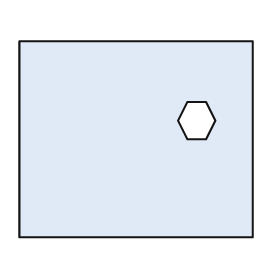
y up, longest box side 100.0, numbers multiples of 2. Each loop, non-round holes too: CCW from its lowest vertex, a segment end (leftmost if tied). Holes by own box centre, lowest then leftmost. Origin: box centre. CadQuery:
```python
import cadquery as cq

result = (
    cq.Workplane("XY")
    .moveTo(-50.0, -42.0)
    .lineTo(50.0, -42.0)
    .lineTo(50.0, 42.0)
    .lineTo(-50.0, 42.0)
    .close()
    .moveTo(22.0, 0.0)
    .lineTo(30.0, 0.0)
    .lineTo(34.0, 8.0)
    .lineTo(30.0, 16.0)
    .lineTo(22.0, 16.0)
    .lineTo(18.0, 8.0)
    .close()
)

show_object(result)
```